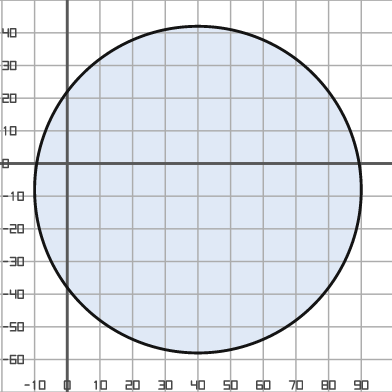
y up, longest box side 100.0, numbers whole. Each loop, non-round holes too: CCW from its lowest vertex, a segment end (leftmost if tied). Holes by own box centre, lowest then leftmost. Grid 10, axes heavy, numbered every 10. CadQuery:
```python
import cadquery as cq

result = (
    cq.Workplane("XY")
    .moveTo(40.0, -8.0)
    .circle(50.0)
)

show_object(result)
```